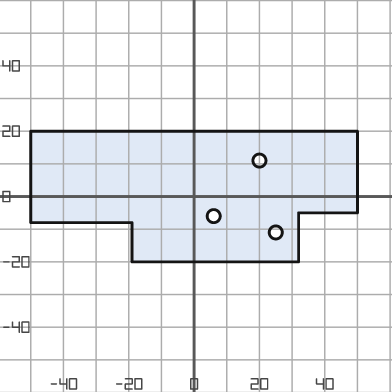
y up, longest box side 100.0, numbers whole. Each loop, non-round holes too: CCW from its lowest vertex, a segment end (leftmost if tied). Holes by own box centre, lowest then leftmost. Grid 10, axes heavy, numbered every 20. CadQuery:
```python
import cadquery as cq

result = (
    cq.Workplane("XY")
    .moveTo(-19.0, -20.0)
    .lineTo(32.0, -20.0)
    .lineTo(32.0, -5.0)
    .lineTo(50.0, -5.0)
    .lineTo(50.0, 20.0)
    .lineTo(-50.0, 20.0)
    .lineTo(-50.0, -8.0)
    .lineTo(-19.0, -8.0)
    .close()
    .moveTo(25.0, -11.0)
    .circle(2.0)
    .moveTo(6.0, -6.0)
    .circle(2.0)
    .moveTo(20.0, 11.0)
    .circle(2.0)
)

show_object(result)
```